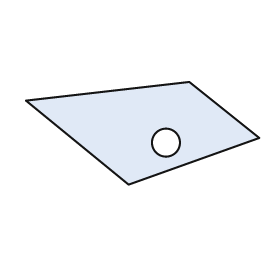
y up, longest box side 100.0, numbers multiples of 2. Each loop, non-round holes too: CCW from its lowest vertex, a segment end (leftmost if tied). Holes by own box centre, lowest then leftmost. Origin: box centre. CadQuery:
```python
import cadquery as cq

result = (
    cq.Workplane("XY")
    .moveTo(-6.0, -22.0)
    .lineTo(50.0, -2.0)
    .lineTo(20.0, 22.0)
    .lineTo(-50.0, 14.0)
    .close()
    .moveTo(10.0, -4.0)
    .circle(6.0)
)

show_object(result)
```